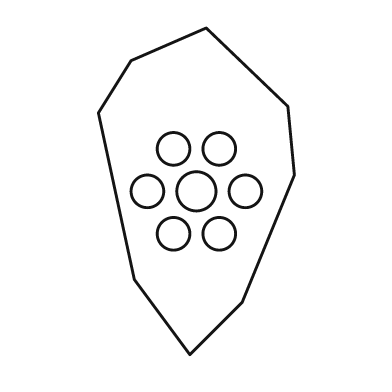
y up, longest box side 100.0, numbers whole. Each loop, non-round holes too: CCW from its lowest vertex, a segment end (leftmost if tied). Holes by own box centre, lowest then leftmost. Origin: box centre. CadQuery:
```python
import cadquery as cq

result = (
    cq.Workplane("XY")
    .moveTo(-2.0, -50.0)
    .lineTo(14.0, -34.0)
    .lineTo(30.0, 5.0)
    .lineTo(28.0, 26.0)
    .lineTo(3.0, 50.0)
    .lineTo(-20.0, 40.0)
    .lineTo(-30.0, 24.0)
    .lineTo(-19.0, -27.0)
    .close()
    .moveTo(-7.0, -13.0)
    .circle(5.0)
    .moveTo(7.0, -13.0)
    .circle(5.0)
    .moveTo(-15.0, 0.0)
    .circle(5.0)
    .moveTo(0.0, 0.0)
    .circle(6.0)
    .moveTo(15.0, 0.0)
    .circle(5.0)
    .moveTo(-7.0, 13.0)
    .circle(5.0)
    .moveTo(7.0, 13.0)
    .circle(5.0)
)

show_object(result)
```